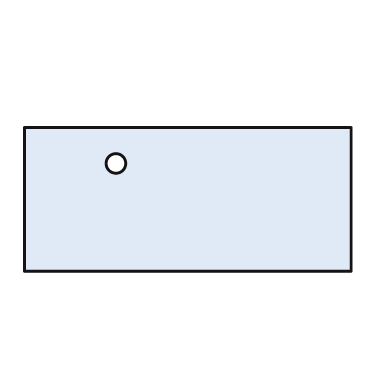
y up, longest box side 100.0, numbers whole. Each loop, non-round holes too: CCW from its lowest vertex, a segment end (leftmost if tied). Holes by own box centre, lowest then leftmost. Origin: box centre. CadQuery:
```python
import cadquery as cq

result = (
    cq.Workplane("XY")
    .moveTo(-50.0, -22.0)
    .lineTo(50.0, -22.0)
    .lineTo(50.0, 22.0)
    .lineTo(-50.0, 22.0)
    .close()
    .moveTo(-22.0, 11.0)
    .circle(3.0)
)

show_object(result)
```